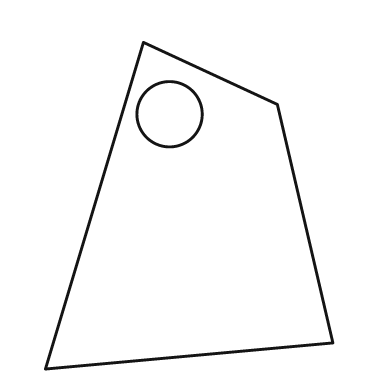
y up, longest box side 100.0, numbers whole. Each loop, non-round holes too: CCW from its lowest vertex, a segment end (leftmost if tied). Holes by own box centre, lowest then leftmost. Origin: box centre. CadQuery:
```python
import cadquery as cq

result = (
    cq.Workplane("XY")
    .moveTo(-44.0, -50.0)
    .lineTo(44.0, -42.0)
    .lineTo(27.0, 31.0)
    .lineTo(-14.0, 50.0)
    .close()
    .moveTo(-6.0, 28.0)
    .circle(10.0)
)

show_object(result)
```